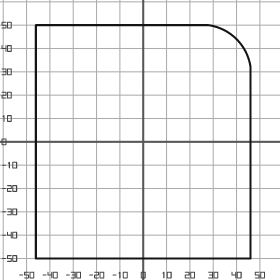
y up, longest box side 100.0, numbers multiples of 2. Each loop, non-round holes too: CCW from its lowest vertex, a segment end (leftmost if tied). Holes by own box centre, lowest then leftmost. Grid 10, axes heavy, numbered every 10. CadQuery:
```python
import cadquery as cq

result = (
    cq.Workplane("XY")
    .moveTo(-46.0, -50.0)
    .lineTo(46.0, -50.0)
    .lineTo(46.0, 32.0)
    .threePointArc((40.0, 44.0), (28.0, 50.0))
    .lineTo(-46.0, 50.0)
    .close()
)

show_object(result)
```